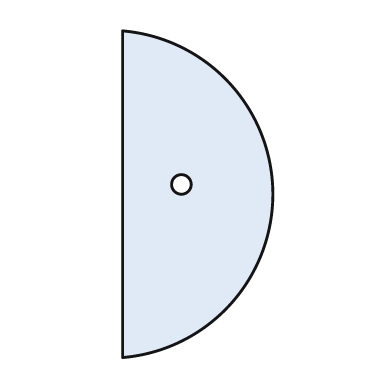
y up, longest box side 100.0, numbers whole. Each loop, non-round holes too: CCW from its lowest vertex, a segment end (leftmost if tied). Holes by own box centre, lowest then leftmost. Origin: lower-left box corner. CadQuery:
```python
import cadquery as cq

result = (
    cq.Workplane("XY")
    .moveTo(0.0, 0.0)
    .threePointArc((46.0, 50.0), (0.0, 100.0))
    .close()
    .moveTo(18.0, 53.0)
    .circle(3.0)
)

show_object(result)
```